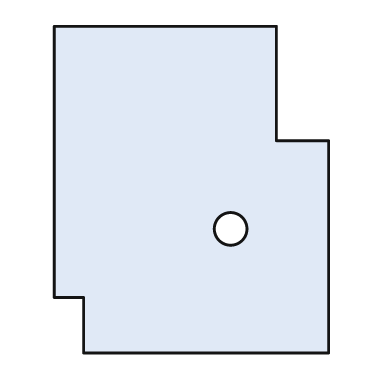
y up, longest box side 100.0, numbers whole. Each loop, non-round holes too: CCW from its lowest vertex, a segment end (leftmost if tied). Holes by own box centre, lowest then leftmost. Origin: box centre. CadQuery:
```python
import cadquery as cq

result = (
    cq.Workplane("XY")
    .moveTo(-33.0, -50.0)
    .lineTo(42.0, -50.0)
    .lineTo(42.0, 15.0)
    .lineTo(26.0, 15.0)
    .lineTo(26.0, 50.0)
    .lineTo(-42.0, 50.0)
    .lineTo(-42.0, -33.0)
    .lineTo(-33.0, -33.0)
    .close()
    .moveTo(12.0, -12.0)
    .circle(5.0)
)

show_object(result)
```